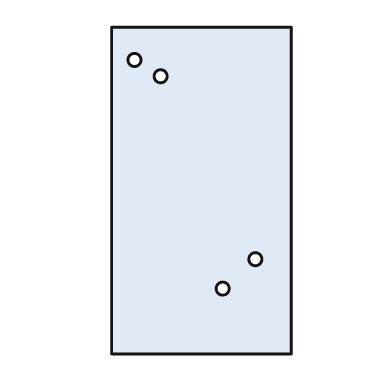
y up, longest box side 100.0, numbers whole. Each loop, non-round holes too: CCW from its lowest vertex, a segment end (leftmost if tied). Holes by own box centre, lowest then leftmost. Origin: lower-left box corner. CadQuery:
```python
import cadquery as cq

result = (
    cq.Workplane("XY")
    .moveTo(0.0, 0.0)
    .lineTo(55.0, 0.0)
    .lineTo(55.0, 100.0)
    .lineTo(0.0, 100.0)
    .close()
    .moveTo(34.0, 20.0)
    .circle(2.0)
    .moveTo(44.0, 29.0)
    .circle(2.0)
    .moveTo(15.0, 85.0)
    .circle(2.0)
    .moveTo(7.0, 90.0)
    .circle(2.0)
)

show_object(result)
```